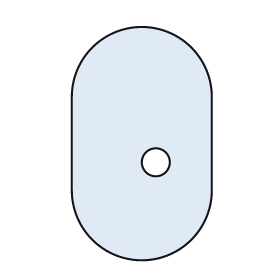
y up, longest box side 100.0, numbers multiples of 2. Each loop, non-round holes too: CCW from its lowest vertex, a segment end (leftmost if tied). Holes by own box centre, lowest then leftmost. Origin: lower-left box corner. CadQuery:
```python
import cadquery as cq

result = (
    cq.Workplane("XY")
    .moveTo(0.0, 30.0)
    .threePointArc((30.0, 0.0), (60.0, 30.0))
    .lineTo(60.0, 70.0)
    .threePointArc((30.0, 100.0), (0.0, 70.0))
    .close()
    .moveTo(36.0, 42.0)
    .circle(6.0)
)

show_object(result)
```